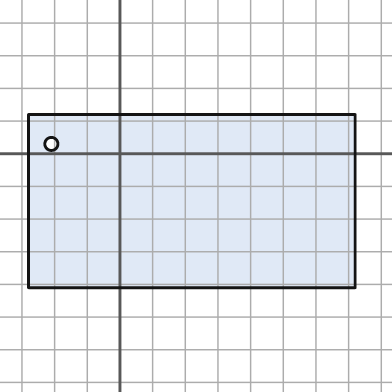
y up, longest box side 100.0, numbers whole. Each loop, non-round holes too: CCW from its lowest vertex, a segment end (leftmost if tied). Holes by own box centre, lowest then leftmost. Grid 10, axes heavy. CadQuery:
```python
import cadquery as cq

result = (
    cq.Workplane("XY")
    .moveTo(-28.0, -41.0)
    .lineTo(72.0, -41.0)
    .lineTo(72.0, 12.0)
    .lineTo(-28.0, 12.0)
    .close()
    .moveTo(-21.0, 3.0)
    .circle(2.0)
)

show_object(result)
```